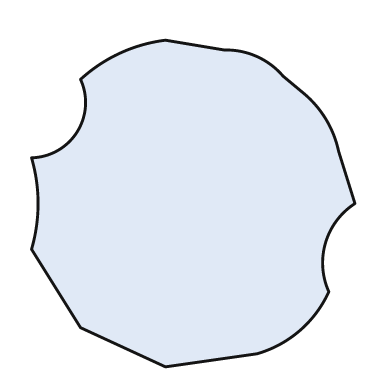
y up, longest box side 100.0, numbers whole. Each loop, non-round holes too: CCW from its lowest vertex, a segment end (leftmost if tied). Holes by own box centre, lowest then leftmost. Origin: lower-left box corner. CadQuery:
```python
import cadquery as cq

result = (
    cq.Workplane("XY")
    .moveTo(41.0, 0.0)
    .lineTo(69.0, 4.0)
    .threePointArc((82.0, 11.0), (91.0, 23.0))
    .threePointArc((90.0, 38.0), (99.0, 50.0))
    .lineTo(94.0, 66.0)
    .threePointArc((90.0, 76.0), (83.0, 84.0))
    .lineTo(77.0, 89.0)
    .threePointArc((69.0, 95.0), (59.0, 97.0))
    .lineTo(41.0, 100.0)
    .threePointArc((27.0, 96.0), (15.0, 88.0))
    .threePointArc((14.0, 72.0), (0.0, 64.0))
    .threePointArc((2.0, 50.0), (0.0, 36.0))
    .lineTo(15.0, 12.0)
    .close()
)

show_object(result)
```